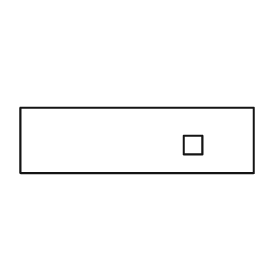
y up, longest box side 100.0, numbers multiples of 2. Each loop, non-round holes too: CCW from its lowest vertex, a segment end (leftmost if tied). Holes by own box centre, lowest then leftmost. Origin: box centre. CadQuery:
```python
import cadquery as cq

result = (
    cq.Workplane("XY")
    .moveTo(-50.0, -14.0)
    .lineTo(50.0, -14.0)
    .lineTo(50.0, 14.0)
    .lineTo(-50.0, 14.0)
    .close()
    .moveTo(20.0, -6.0)
    .lineTo(28.0, -6.0)
    .lineTo(28.0, 2.0)
    .lineTo(20.0, 2.0)
    .close()
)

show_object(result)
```